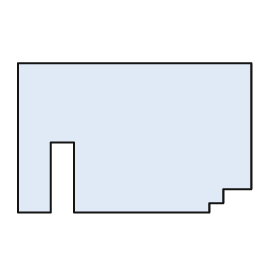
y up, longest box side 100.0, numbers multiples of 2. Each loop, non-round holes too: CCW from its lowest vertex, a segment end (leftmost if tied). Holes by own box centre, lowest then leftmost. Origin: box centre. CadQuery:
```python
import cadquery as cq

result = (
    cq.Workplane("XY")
    .moveTo(-50.0, -32.0)
    .lineTo(-36.0, -32.0)
    .lineTo(-36.0, -2.0)
    .lineTo(-26.0, -2.0)
    .lineTo(-26.0, -32.0)
    .lineTo(32.0, -32.0)
    .lineTo(32.0, -28.0)
    .lineTo(38.0, -28.0)
    .lineTo(38.0, -22.0)
    .lineTo(50.0, -22.0)
    .lineTo(50.0, 32.0)
    .lineTo(-50.0, 32.0)
    .close()
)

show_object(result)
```